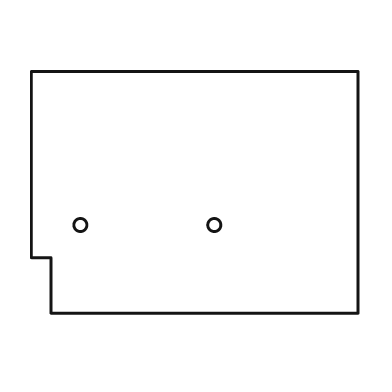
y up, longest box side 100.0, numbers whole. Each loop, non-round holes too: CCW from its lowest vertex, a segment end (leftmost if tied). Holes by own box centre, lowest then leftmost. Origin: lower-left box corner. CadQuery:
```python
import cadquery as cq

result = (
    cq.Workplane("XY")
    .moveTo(6.0, 0.0)
    .lineTo(100.0, 0.0)
    .lineTo(100.0, 74.0)
    .lineTo(0.0, 74.0)
    .lineTo(0.0, 17.0)
    .lineTo(6.0, 17.0)
    .close()
    .moveTo(15.0, 27.0)
    .circle(2.0)
    .moveTo(56.0, 27.0)
    .circle(2.0)
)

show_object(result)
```